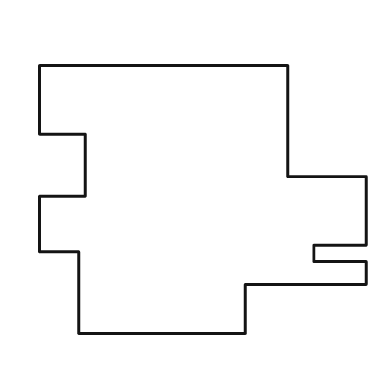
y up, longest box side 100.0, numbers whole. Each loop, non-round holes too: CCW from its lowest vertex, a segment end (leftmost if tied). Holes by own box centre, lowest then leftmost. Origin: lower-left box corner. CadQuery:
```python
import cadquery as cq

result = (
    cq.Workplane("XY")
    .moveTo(12.0, 0.0)
    .lineTo(63.0, 0.0)
    .lineTo(63.0, 15.0)
    .lineTo(100.0, 15.0)
    .lineTo(100.0, 22.0)
    .lineTo(84.0, 22.0)
    .lineTo(84.0, 27.0)
    .lineTo(100.0, 27.0)
    .lineTo(100.0, 48.0)
    .lineTo(76.0, 48.0)
    .lineTo(76.0, 82.0)
    .lineTo(0.0, 82.0)
    .lineTo(0.0, 61.0)
    .lineTo(14.0, 61.0)
    .lineTo(14.0, 42.0)
    .lineTo(0.0, 42.0)
    .lineTo(0.0, 25.0)
    .lineTo(12.0, 25.0)
    .close()
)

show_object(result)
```